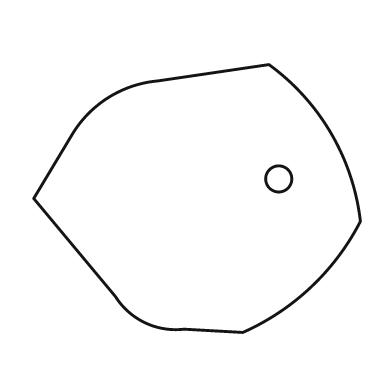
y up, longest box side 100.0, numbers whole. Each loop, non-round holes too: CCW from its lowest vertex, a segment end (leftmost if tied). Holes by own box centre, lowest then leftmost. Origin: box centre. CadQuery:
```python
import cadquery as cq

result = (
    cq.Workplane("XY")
    .moveTo(14.0, -41.0)
    .threePointArc((35.0, -27.0), (50.0, -7.0))
    .threePointArc((41.0, 20.0), (22.0, 41.0))
    .lineTo(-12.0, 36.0)
    .threePointArc((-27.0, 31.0), (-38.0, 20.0))
    .lineTo(-50.0, 0.0)
    .lineTo(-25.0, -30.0)
    .threePointArc((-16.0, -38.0), (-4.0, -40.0))
    .close()
    .moveTo(25.0, 6.0)
    .circle(4.0)
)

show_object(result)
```